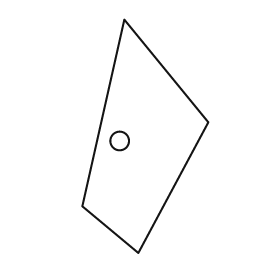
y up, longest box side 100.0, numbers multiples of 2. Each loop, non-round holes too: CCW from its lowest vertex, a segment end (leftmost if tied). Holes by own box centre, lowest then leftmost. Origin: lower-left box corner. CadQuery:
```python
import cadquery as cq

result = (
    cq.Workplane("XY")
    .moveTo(24.0, 0.0)
    .lineTo(54.0, 56.0)
    .lineTo(18.0, 100.0)
    .lineTo(0.0, 20.0)
    .close()
    .moveTo(16.0, 48.0)
    .circle(4.0)
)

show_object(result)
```